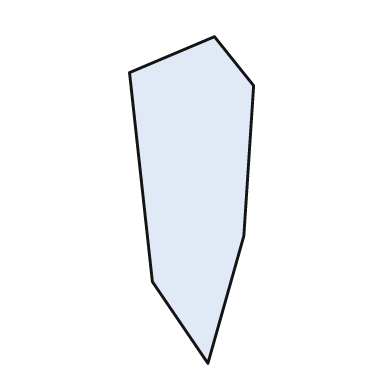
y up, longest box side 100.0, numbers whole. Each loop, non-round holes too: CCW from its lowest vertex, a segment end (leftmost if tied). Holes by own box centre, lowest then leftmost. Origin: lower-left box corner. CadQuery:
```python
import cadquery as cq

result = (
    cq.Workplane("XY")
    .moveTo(24.0, 0.0)
    .lineTo(35.0, 39.0)
    .lineTo(38.0, 85.0)
    .lineTo(26.0, 100.0)
    .lineTo(0.0, 89.0)
    .lineTo(7.0, 25.0)
    .close()
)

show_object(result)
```